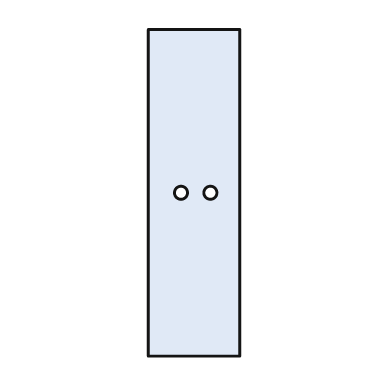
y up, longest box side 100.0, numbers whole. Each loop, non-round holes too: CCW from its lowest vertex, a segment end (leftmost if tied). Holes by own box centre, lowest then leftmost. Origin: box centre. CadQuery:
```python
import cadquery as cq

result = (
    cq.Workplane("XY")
    .moveTo(-14.0, -50.0)
    .lineTo(14.0, -50.0)
    .lineTo(14.0, 50.0)
    .lineTo(-14.0, 50.0)
    .close()
    .moveTo(-4.0, 0.0)
    .circle(2.0)
    .moveTo(5.0, 0.0)
    .circle(2.0)
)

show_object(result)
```